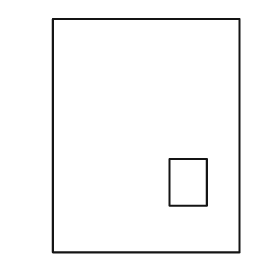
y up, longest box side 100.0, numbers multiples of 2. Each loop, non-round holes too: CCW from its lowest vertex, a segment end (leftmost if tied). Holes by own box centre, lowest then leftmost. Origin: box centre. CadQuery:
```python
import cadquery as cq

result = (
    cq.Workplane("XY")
    .moveTo(-40.0, -50.0)
    .lineTo(40.0, -50.0)
    .lineTo(40.0, 50.0)
    .lineTo(-40.0, 50.0)
    .close()
    .moveTo(10.0, -30.0)
    .lineTo(26.0, -30.0)
    .lineTo(26.0, -10.0)
    .lineTo(10.0, -10.0)
    .close()
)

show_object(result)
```